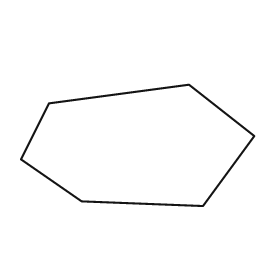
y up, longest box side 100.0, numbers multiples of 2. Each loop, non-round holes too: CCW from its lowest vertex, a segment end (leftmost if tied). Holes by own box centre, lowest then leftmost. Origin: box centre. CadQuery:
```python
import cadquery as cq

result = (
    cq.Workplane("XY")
    .moveTo(28.0, -26.0)
    .lineTo(50.0, 4.0)
    .lineTo(22.0, 26.0)
    .lineTo(-38.0, 18.0)
    .lineTo(-50.0, -6.0)
    .lineTo(-24.0, -24.0)
    .close()
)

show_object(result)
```